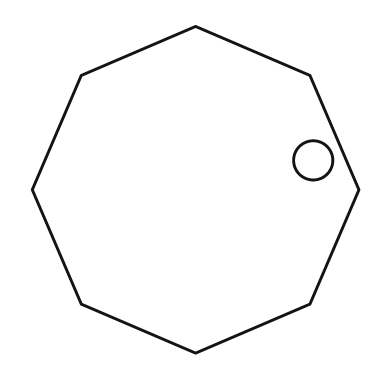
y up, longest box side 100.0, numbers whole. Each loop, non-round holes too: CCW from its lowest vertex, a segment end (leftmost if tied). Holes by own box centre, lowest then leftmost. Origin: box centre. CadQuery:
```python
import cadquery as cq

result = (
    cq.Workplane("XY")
    .moveTo(0.0, -50.0)
    .lineTo(35.0, -35.0)
    .lineTo(50.0, 0.0)
    .lineTo(35.0, 35.0)
    .lineTo(0.0, 50.0)
    .lineTo(-35.0, 35.0)
    .lineTo(-50.0, 0.0)
    .lineTo(-35.0, -35.0)
    .close()
    .moveTo(36.0, 9.0)
    .circle(6.0)
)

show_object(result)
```